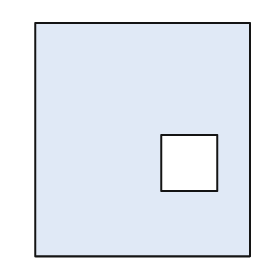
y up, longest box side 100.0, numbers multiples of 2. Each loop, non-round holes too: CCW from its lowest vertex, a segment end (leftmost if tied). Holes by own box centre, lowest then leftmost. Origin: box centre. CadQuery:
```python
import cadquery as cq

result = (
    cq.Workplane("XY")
    .moveTo(-46.0, -50.0)
    .lineTo(46.0, -50.0)
    .lineTo(46.0, 50.0)
    .lineTo(-46.0, 50.0)
    .close()
    .moveTo(8.0, -22.0)
    .lineTo(32.0, -22.0)
    .lineTo(32.0, 2.0)
    .lineTo(8.0, 2.0)
    .close()
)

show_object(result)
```